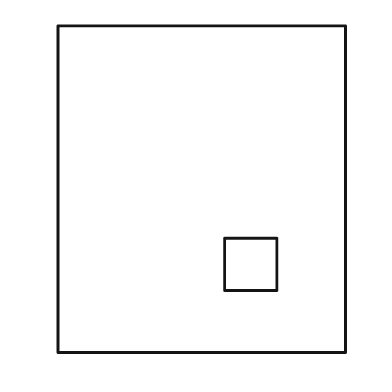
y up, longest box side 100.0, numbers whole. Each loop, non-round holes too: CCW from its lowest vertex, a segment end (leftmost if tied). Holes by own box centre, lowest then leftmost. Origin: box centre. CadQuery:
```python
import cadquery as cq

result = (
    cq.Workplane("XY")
    .moveTo(-44.0, -50.0)
    .lineTo(44.0, -50.0)
    .lineTo(44.0, 50.0)
    .lineTo(-44.0, 50.0)
    .close()
    .moveTo(7.0, -31.0)
    .lineTo(23.0, -31.0)
    .lineTo(23.0, -15.0)
    .lineTo(7.0, -15.0)
    .close()
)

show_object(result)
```